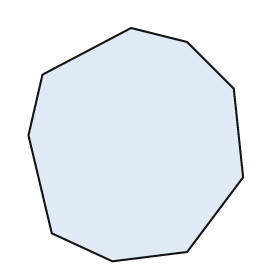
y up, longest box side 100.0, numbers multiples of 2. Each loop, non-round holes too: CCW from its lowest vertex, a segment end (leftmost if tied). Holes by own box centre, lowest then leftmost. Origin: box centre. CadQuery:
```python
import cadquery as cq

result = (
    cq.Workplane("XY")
    .moveTo(-10.0, -50.0)
    .lineTo(22.0, -46.0)
    .lineTo(46.0, -14.0)
    .lineTo(42.0, 24.0)
    .lineTo(22.0, 44.0)
    .lineTo(-2.0, 50.0)
    .lineTo(-40.0, 30.0)
    .lineTo(-46.0, 4.0)
    .lineTo(-36.0, -38.0)
    .close()
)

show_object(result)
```